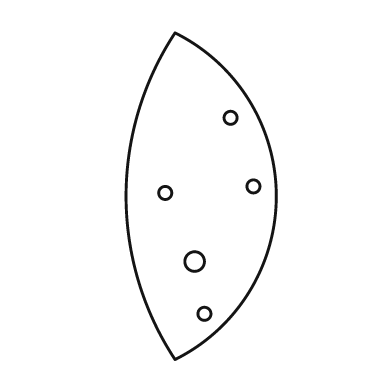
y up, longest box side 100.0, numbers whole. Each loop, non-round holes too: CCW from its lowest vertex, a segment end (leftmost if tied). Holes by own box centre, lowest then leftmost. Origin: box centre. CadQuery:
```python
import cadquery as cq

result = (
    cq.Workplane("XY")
    .moveTo(-8.0, -50.0)
    .threePointArc((23.0, 0.0), (-8.0, 50.0))
    .threePointArc((-23.0, 0.0), (-8.0, -50.0))
    .close()
    .moveTo(1.0, -36.0)
    .circle(2.0)
    .moveTo(-2.0, -20.0)
    .circle(3.0)
    .moveTo(-11.0, 1.0)
    .circle(2.0)
    .moveTo(16.0, 3.0)
    .circle(2.0)
    .moveTo(9.0, 24.0)
    .circle(2.0)
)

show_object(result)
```